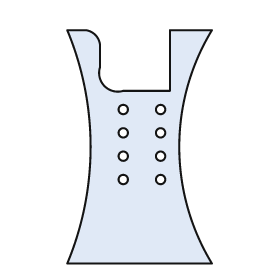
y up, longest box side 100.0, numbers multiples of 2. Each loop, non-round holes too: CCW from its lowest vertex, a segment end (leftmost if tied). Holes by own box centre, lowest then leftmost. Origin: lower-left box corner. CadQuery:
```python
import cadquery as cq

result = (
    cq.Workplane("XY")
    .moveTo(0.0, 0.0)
    .lineTo(62.0, 0.0)
    .threePointArc((48.0, 50.0), (62.0, 100.0))
    .lineTo(44.0, 100.0)
    .lineTo(44.0, 74.0)
    .lineTo(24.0, 74.0)
    .threePointArc((16.0, 76.0), (14.0, 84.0))
    .lineTo(14.0, 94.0)
    .threePointArc((12.0, 98.0), (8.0, 100.0))
    .lineTo(0.0, 100.0)
    .threePointArc((10.0, 50.0), (0.0, 0.0))
    .close()
    .moveTo(24.0, 36.0)
    .circle(2.0)
    .moveTo(40.0, 36.0)
    .circle(2.0)
    .moveTo(24.0, 46.0)
    .circle(2.0)
    .moveTo(40.0, 46.0)
    .circle(2.0)
    .moveTo(24.0, 56.0)
    .circle(2.0)
    .moveTo(40.0, 56.0)
    .circle(2.0)
    .moveTo(24.0, 66.0)
    .circle(2.0)
    .moveTo(40.0, 66.0)
    .circle(2.0)
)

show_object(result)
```